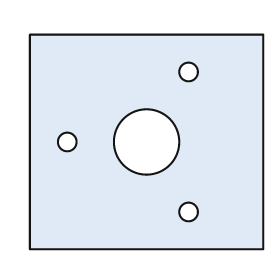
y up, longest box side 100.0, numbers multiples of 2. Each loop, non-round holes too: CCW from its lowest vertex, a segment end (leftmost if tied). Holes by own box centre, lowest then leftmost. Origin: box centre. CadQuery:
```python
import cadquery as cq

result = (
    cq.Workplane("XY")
    .moveTo(-50.0, -46.0)
    .lineTo(50.0, -46.0)
    .lineTo(50.0, 46.0)
    .lineTo(-50.0, 46.0)
    .close()
    .moveTo(18.0, -30.0)
    .circle(4.0)
    .moveTo(-34.0, 0.0)
    .circle(4.0)
    .moveTo(0.0, 0.0)
    .circle(14.0)
    .moveTo(18.0, 30.0)
    .circle(4.0)
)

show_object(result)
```